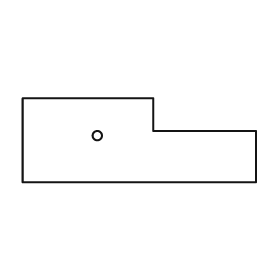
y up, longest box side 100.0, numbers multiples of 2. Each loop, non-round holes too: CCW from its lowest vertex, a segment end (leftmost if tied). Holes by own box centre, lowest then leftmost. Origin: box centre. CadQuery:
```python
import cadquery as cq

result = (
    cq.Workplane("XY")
    .moveTo(-50.0, -18.0)
    .lineTo(50.0, -18.0)
    .lineTo(50.0, 4.0)
    .lineTo(6.0, 4.0)
    .lineTo(6.0, 18.0)
    .lineTo(-50.0, 18.0)
    .close()
    .moveTo(-18.0, 2.0)
    .circle(2.0)
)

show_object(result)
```